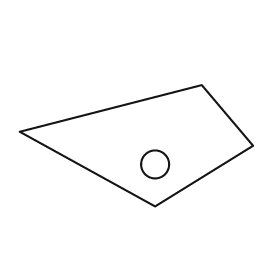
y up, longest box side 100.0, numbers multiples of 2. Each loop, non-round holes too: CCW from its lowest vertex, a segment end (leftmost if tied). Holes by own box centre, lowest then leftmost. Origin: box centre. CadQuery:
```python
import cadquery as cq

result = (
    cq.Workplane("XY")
    .moveTo(8.0, -26.0)
    .lineTo(50.0, 0.0)
    .lineTo(28.0, 26.0)
    .lineTo(-50.0, 6.0)
    .close()
    .moveTo(8.0, -8.0)
    .circle(6.0)
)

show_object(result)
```